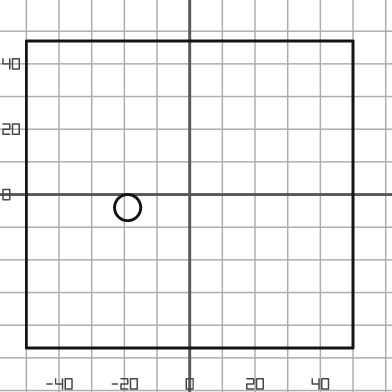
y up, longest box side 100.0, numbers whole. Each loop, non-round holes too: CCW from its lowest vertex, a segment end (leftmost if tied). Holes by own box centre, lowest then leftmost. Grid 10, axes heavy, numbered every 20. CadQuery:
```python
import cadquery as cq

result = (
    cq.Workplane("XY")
    .moveTo(-50.0, -47.0)
    .lineTo(50.0, -47.0)
    .lineTo(50.0, 47.0)
    .lineTo(-50.0, 47.0)
    .close()
    .moveTo(-19.0, -4.0)
    .circle(4.0)
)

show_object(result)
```